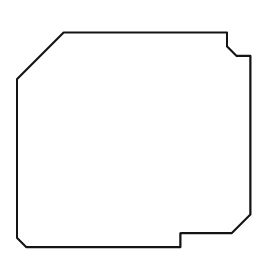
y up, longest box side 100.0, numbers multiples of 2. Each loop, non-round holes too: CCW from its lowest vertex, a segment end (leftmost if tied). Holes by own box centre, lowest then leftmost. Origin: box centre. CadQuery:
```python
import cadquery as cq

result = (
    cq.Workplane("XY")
    .moveTo(-46.0, -46.0)
    .lineTo(20.0, -46.0)
    .lineTo(20.0, -40.0)
    .lineTo(42.0, -40.0)
    .lineTo(50.0, -32.0)
    .lineTo(50.0, 36.0)
    .lineTo(44.0, 36.0)
    .lineTo(40.0, 40.0)
    .lineTo(40.0, 46.0)
    .lineTo(-30.0, 46.0)
    .lineTo(-50.0, 26.0)
    .lineTo(-50.0, -42.0)
    .close()
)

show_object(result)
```